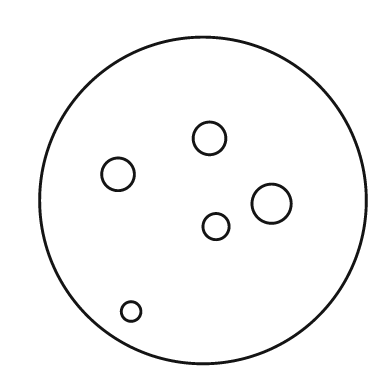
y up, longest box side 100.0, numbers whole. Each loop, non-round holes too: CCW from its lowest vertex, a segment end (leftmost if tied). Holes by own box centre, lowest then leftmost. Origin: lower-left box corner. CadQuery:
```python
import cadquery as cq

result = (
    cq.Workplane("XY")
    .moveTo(50.0, 50.0)
    .circle(50.0)
    .moveTo(28.0, 16.0)
    .circle(3.0)
    .moveTo(54.0, 42.0)
    .circle(4.0)
    .moveTo(71.0, 49.0)
    .circle(6.0)
    .moveTo(24.0, 58.0)
    .circle(5.0)
    .moveTo(52.0, 69.0)
    .circle(5.0)
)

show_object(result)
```